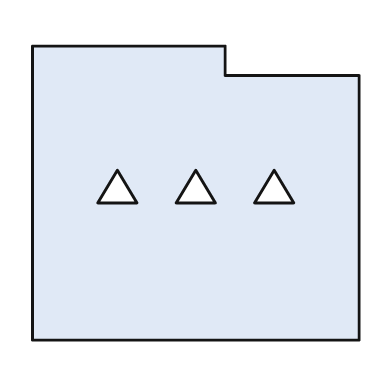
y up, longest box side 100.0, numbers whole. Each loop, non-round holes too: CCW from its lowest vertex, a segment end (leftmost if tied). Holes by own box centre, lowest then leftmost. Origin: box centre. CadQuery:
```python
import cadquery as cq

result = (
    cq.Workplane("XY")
    .moveTo(-50.0, -45.0)
    .lineTo(50.0, -45.0)
    .lineTo(50.0, 36.0)
    .lineTo(9.0, 36.0)
    .lineTo(9.0, 45.0)
    .lineTo(-50.0, 45.0)
    .close()
    .moveTo(-30.0, -3.0)
    .lineTo(-18.0, -3.0)
    .lineTo(-24.0, 7.0)
    .close()
    .moveTo(-6.0, -3.0)
    .lineTo(6.0, -3.0)
    .lineTo(0.0, 7.0)
    .close()
    .moveTo(18.0, -3.0)
    .lineTo(30.0, -3.0)
    .lineTo(24.0, 7.0)
    .close()
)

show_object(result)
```